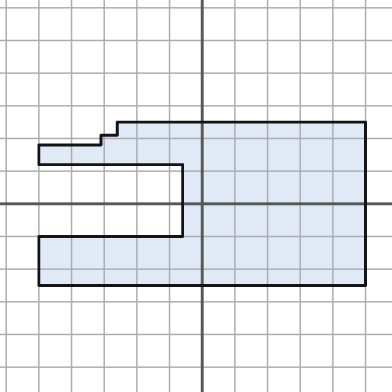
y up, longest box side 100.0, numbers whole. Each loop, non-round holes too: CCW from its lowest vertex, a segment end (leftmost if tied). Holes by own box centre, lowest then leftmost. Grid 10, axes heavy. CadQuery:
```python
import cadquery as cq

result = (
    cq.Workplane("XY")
    .moveTo(-50.0, -25.0)
    .lineTo(50.0, -25.0)
    .lineTo(50.0, 25.0)
    .lineTo(-26.0, 25.0)
    .lineTo(-26.0, 21.0)
    .lineTo(-31.0, 21.0)
    .lineTo(-31.0, 18.0)
    .lineTo(-50.0, 18.0)
    .lineTo(-50.0, 12.0)
    .lineTo(-6.0, 12.0)
    .lineTo(-6.0, -10.0)
    .lineTo(-50.0, -10.0)
    .close()
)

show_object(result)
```